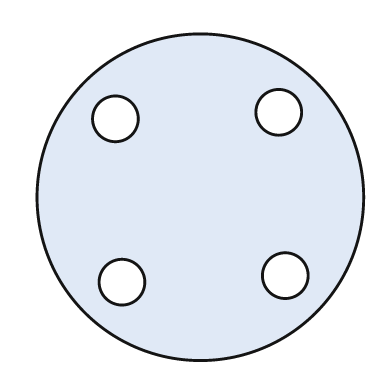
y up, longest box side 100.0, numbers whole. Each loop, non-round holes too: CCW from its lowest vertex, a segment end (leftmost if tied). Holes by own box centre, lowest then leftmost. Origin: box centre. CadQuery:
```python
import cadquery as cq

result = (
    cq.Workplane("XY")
    .moveTo(0.0, 0.0)
    .circle(50.0)
    .moveTo(-24.0, -26.0)
    .circle(7.0)
    .moveTo(26.0, -24.0)
    .circle(7.0)
    .moveTo(-26.0, 24.0)
    .circle(7.0)
    .moveTo(24.0, 26.0)
    .circle(7.0)
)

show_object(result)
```